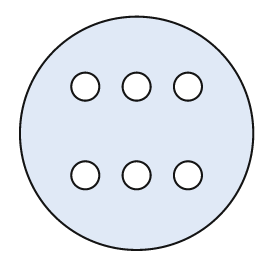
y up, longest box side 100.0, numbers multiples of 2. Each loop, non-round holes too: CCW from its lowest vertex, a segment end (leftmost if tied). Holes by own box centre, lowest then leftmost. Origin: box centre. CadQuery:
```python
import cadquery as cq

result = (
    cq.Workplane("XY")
    .moveTo(0.0, 0.0)
    .circle(50.0)
    .moveTo(-22.0, -18.0)
    .circle(6.0)
    .moveTo(0.0, -18.0)
    .circle(6.0)
    .moveTo(22.0, -18.0)
    .circle(6.0)
    .moveTo(-22.0, 20.0)
    .circle(6.0)
    .moveTo(0.0, 20.0)
    .circle(6.0)
    .moveTo(22.0, 20.0)
    .circle(6.0)
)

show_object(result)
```